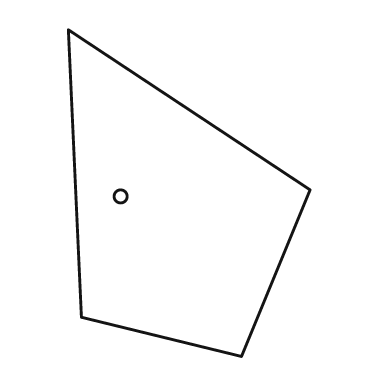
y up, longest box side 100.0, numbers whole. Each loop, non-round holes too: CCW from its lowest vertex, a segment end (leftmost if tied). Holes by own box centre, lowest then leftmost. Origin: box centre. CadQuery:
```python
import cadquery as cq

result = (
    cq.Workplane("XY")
    .moveTo(16.0, -50.0)
    .lineTo(37.0, 1.0)
    .lineTo(-37.0, 50.0)
    .lineTo(-33.0, -38.0)
    .close()
    .moveTo(-21.0, -1.0)
    .circle(2.0)
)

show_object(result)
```